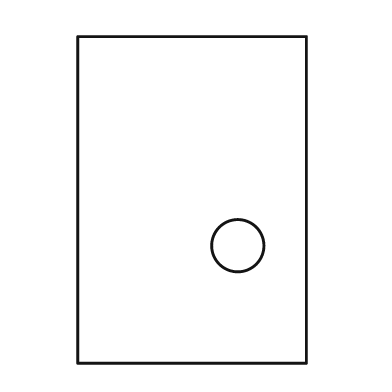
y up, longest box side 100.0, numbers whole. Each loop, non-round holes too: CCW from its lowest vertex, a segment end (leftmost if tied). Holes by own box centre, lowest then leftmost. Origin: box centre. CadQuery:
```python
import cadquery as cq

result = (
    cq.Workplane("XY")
    .moveTo(-35.0, -50.0)
    .lineTo(35.0, -50.0)
    .lineTo(35.0, 50.0)
    .lineTo(-35.0, 50.0)
    .close()
    .moveTo(14.0, -14.0)
    .circle(8.0)
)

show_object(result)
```